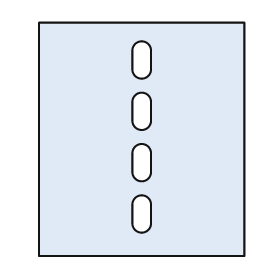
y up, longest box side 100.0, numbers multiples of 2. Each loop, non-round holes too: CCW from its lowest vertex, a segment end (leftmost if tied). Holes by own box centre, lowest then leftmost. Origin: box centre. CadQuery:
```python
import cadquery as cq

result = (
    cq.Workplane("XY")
    .moveTo(-44.0, -50.0)
    .lineTo(44.0, -50.0)
    .lineTo(44.0, 50.0)
    .lineTo(-44.0, 50.0)
    .close()
    .moveTo(-4.0, -36.0)
    .threePointArc((0.0, -40.0), (4.0, -36.0))
    .lineTo(4.0, -28.0)
    .threePointArc((0.0, -24.0), (-4.0, -28.0))
    .close()
    .moveTo(-4.0, -14.0)
    .threePointArc((0.0, -18.0), (4.0, -14.0))
    .lineTo(4.0, -6.0)
    .threePointArc((0.0, -2.0), (-4.0, -6.0))
    .close()
    .moveTo(-4.0, 8.0)
    .threePointArc((0.0, 4.0), (4.0, 8.0))
    .lineTo(4.0, 16.0)
    .threePointArc((0.0, 20.0), (-4.0, 16.0))
    .close()
    .moveTo(-4.0, 30.0)
    .threePointArc((0.0, 26.0), (4.0, 30.0))
    .lineTo(4.0, 38.0)
    .threePointArc((0.0, 42.0), (-4.0, 38.0))
    .close()
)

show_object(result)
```